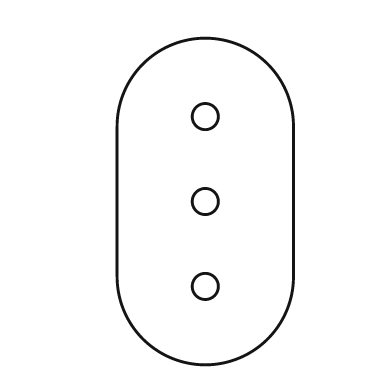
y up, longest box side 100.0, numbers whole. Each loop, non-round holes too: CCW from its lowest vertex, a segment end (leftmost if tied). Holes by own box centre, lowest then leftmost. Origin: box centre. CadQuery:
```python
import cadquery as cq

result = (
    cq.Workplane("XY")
    .moveTo(-27.0, -23.0)
    .threePointArc((0.0, -50.0), (27.0, -23.0))
    .lineTo(27.0, 23.0)
    .threePointArc((0.0, 50.0), (-27.0, 23.0))
    .close()
    .moveTo(0.0, -26.0)
    .circle(4.0)
    .moveTo(0.0, 0.0)
    .circle(4.0)
    .moveTo(0.0, 26.0)
    .circle(4.0)
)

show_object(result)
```